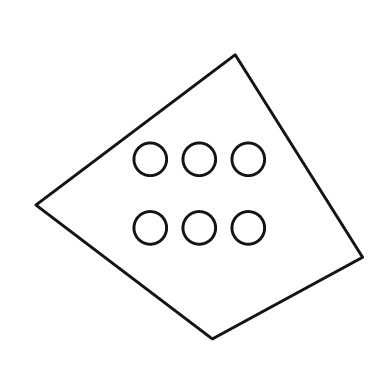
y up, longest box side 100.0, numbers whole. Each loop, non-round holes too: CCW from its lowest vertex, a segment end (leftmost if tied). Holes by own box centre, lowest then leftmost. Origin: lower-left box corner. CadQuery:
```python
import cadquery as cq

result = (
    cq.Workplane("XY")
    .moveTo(54.0, 0.0)
    .lineTo(100.0, 25.0)
    .lineTo(61.0, 87.0)
    .lineTo(0.0, 41.0)
    .close()
    .moveTo(35.0, 34.0)
    .circle(5.0)
    .moveTo(50.0, 34.0)
    .circle(5.0)
    .moveTo(65.0, 34.0)
    .circle(5.0)
    .moveTo(35.0, 55.0)
    .circle(5.0)
    .moveTo(50.0, 55.0)
    .circle(5.0)
    .moveTo(65.0, 55.0)
    .circle(5.0)
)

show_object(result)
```